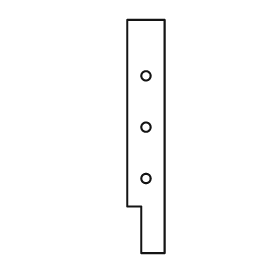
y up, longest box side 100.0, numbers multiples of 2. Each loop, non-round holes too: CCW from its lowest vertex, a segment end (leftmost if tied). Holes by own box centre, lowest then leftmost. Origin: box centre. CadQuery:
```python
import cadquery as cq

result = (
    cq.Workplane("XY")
    .moveTo(-2.0, -50.0)
    .lineTo(8.0, -50.0)
    .lineTo(8.0, 50.0)
    .lineTo(-8.0, 50.0)
    .lineTo(-8.0, -30.0)
    .lineTo(-2.0, -30.0)
    .close()
    .moveTo(0.0, -18.0)
    .circle(2.0)
    .moveTo(0.0, 4.0)
    .circle(2.0)
    .moveTo(0.0, 26.0)
    .circle(2.0)
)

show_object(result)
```